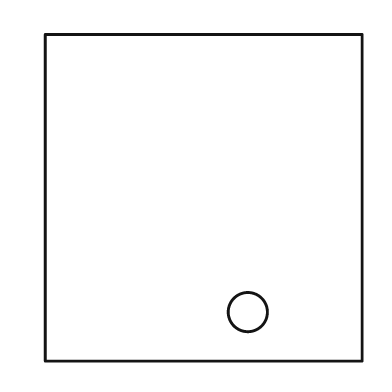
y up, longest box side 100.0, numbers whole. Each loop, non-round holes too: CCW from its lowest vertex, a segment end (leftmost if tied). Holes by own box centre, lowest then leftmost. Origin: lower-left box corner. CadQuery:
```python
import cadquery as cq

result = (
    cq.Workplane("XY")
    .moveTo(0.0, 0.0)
    .lineTo(97.0, 0.0)
    .lineTo(97.0, 100.0)
    .lineTo(0.0, 100.0)
    .close()
    .moveTo(62.0, 15.0)
    .circle(6.0)
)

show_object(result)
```